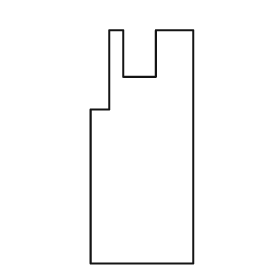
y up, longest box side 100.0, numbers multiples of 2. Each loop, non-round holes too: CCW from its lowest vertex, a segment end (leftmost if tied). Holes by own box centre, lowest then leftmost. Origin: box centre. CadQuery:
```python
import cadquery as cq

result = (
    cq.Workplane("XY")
    .moveTo(-22.0, -50.0)
    .lineTo(22.0, -50.0)
    .lineTo(22.0, 50.0)
    .lineTo(6.0, 50.0)
    .lineTo(6.0, 30.0)
    .lineTo(-8.0, 30.0)
    .lineTo(-8.0, 50.0)
    .lineTo(-14.0, 50.0)
    .lineTo(-14.0, 16.0)
    .lineTo(-22.0, 16.0)
    .close()
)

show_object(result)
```